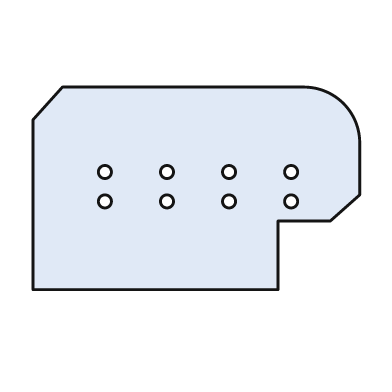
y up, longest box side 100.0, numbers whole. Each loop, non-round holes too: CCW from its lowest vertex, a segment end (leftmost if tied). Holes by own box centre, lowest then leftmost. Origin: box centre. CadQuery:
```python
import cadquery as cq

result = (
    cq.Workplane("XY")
    .moveTo(-50.0, -31.0)
    .lineTo(25.0, -31.0)
    .lineTo(25.0, -10.0)
    .lineTo(41.0, -10.0)
    .lineTo(50.0, -2.0)
    .lineTo(50.0, 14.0)
    .threePointArc((45.0, 26.0), (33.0, 31.0))
    .lineTo(-41.0, 31.0)
    .lineTo(-50.0, 21.0)
    .close()
    .moveTo(-28.0, -4.0)
    .circle(2.0)
    .moveTo(-9.0, -4.0)
    .circle(2.0)
    .moveTo(10.0, -4.0)
    .circle(2.0)
    .moveTo(29.0, -4.0)
    .circle(2.0)
    .moveTo(-28.0, 5.0)
    .circle(2.0)
    .moveTo(-9.0, 5.0)
    .circle(2.0)
    .moveTo(10.0, 5.0)
    .circle(2.0)
    .moveTo(29.0, 5.0)
    .circle(2.0)
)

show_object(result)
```